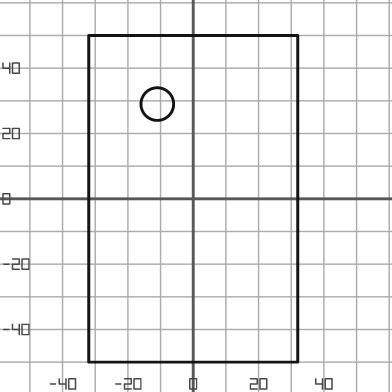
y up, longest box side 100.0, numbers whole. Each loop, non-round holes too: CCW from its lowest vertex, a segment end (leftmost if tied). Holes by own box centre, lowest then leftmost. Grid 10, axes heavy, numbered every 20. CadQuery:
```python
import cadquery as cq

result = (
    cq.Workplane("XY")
    .moveTo(-32.0, -50.0)
    .lineTo(32.0, -50.0)
    .lineTo(32.0, 50.0)
    .lineTo(-32.0, 50.0)
    .close()
    .moveTo(-11.0, 29.0)
    .circle(5.0)
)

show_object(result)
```